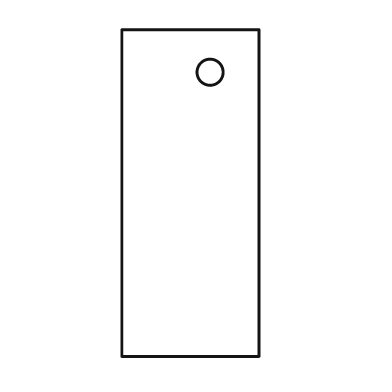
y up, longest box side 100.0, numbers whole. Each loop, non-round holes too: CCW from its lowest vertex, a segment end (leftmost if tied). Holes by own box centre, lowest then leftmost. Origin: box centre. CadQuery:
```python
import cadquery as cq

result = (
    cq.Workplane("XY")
    .moveTo(-21.0, -50.0)
    .lineTo(21.0, -50.0)
    .lineTo(21.0, 50.0)
    .lineTo(-21.0, 50.0)
    .close()
    .moveTo(6.0, 37.0)
    .circle(4.0)
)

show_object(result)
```